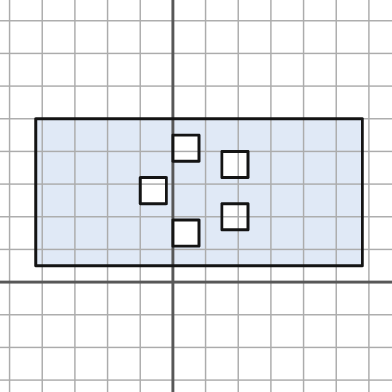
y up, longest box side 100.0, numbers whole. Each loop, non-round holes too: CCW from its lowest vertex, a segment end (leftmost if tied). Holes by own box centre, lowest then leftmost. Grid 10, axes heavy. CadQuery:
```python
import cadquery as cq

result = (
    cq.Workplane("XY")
    .moveTo(-42.0, 5.0)
    .lineTo(58.0, 5.0)
    .lineTo(58.0, 50.0)
    .lineTo(-42.0, 50.0)
    .close()
    .moveTo(0.0, 11.0)
    .lineTo(8.0, 11.0)
    .lineTo(8.0, 19.0)
    .lineTo(0.0, 19.0)
    .close()
    .moveTo(15.0, 16.0)
    .lineTo(23.0, 16.0)
    .lineTo(23.0, 24.0)
    .lineTo(15.0, 24.0)
    .close()
    .moveTo(-10.0, 24.0)
    .lineTo(-2.0, 24.0)
    .lineTo(-2.0, 32.0)
    .lineTo(-10.0, 32.0)
    .close()
    .moveTo(15.0, 32.0)
    .lineTo(23.0, 32.0)
    .lineTo(23.0, 40.0)
    .lineTo(15.0, 40.0)
    .close()
    .moveTo(0.0, 37.0)
    .lineTo(8.0, 37.0)
    .lineTo(8.0, 45.0)
    .lineTo(0.0, 45.0)
    .close()
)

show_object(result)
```